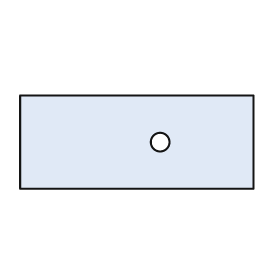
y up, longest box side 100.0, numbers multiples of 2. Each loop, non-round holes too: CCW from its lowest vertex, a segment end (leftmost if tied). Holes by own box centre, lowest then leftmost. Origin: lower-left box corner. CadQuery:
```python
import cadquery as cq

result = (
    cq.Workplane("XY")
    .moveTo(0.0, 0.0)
    .lineTo(100.0, 0.0)
    .lineTo(100.0, 40.0)
    .lineTo(0.0, 40.0)
    .close()
    .moveTo(60.0, 20.0)
    .circle(4.0)
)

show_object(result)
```